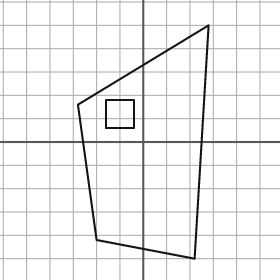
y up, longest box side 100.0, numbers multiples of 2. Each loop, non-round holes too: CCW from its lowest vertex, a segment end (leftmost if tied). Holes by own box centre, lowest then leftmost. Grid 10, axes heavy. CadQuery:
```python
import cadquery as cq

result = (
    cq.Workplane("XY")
    .moveTo(22.0, -50.0)
    .lineTo(28.0, 50.0)
    .lineTo(-28.0, 16.0)
    .lineTo(-20.0, -42.0)
    .close()
    .moveTo(-16.0, 6.0)
    .lineTo(-4.0, 6.0)
    .lineTo(-4.0, 18.0)
    .lineTo(-16.0, 18.0)
    .close()
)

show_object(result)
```